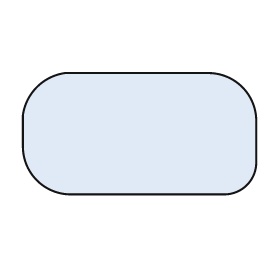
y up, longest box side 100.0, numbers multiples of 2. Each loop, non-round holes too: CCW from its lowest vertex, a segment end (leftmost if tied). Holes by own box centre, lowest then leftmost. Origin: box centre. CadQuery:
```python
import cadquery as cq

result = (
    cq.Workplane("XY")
    .moveTo(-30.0, -26.0)
    .lineTo(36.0, -26.0)
    .threePointArc((46.0, -22.0), (50.0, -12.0))
    .lineTo(50.0, 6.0)
    .threePointArc((44.0, 20.0), (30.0, 26.0))
    .lineTo(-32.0, 26.0)
    .threePointArc((-44.0, 20.0), (-50.0, 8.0))
    .lineTo(-50.0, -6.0)
    .threePointArc((-44.0, -20.0), (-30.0, -26.0))
    .close()
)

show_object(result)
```